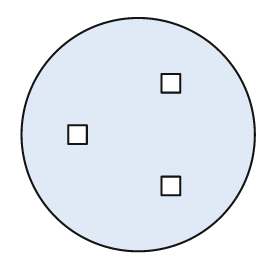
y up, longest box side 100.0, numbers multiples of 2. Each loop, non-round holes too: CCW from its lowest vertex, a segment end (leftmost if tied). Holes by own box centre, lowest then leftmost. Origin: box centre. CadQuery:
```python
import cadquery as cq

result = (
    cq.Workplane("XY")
    .moveTo(0.0, 0.0)
    .circle(50.0)
    .moveTo(10.0, -26.0)
    .lineTo(18.0, -26.0)
    .lineTo(18.0, -18.0)
    .lineTo(10.0, -18.0)
    .close()
    .moveTo(-30.0, -4.0)
    .lineTo(-22.0, -4.0)
    .lineTo(-22.0, 4.0)
    .lineTo(-30.0, 4.0)
    .close()
    .moveTo(10.0, 18.0)
    .lineTo(18.0, 18.0)
    .lineTo(18.0, 26.0)
    .lineTo(10.0, 26.0)
    .close()
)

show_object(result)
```